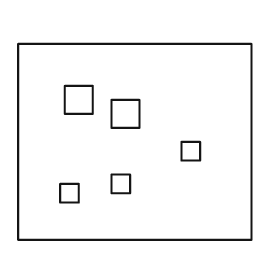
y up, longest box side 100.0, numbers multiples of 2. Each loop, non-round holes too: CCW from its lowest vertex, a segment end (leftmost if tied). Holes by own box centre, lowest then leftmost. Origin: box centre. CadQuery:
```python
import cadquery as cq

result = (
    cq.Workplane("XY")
    .moveTo(-50.0, -42.0)
    .lineTo(50.0, -42.0)
    .lineTo(50.0, 42.0)
    .lineTo(-50.0, 42.0)
    .close()
    .moveTo(-32.0, -26.0)
    .lineTo(-24.0, -26.0)
    .lineTo(-24.0, -18.0)
    .lineTo(-32.0, -18.0)
    .close()
    .moveTo(-10.0, -22.0)
    .lineTo(-2.0, -22.0)
    .lineTo(-2.0, -14.0)
    .lineTo(-10.0, -14.0)
    .close()
    .moveTo(20.0, -8.0)
    .lineTo(28.0, -8.0)
    .lineTo(28.0, 0.0)
    .lineTo(20.0, 0.0)
    .close()
    .moveTo(-10.0, 6.0)
    .lineTo(2.0, 6.0)
    .lineTo(2.0, 18.0)
    .lineTo(-10.0, 18.0)
    .close()
    .moveTo(-30.0, 12.0)
    .lineTo(-18.0, 12.0)
    .lineTo(-18.0, 24.0)
    .lineTo(-30.0, 24.0)
    .close()
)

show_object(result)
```